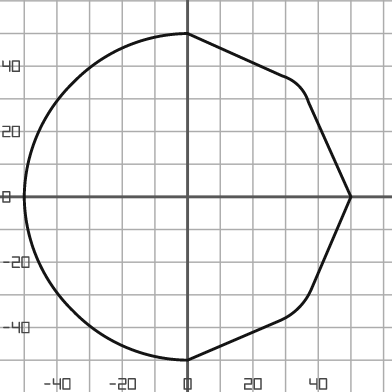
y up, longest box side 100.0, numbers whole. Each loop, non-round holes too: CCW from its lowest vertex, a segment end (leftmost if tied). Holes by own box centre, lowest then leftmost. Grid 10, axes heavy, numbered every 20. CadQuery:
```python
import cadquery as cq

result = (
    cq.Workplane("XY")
    .moveTo(0.0, -50.0)
    .lineTo(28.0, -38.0)
    .threePointArc((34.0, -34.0), (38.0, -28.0))
    .lineTo(50.0, 0.0)
    .lineTo(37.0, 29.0)
    .threePointArc((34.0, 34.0), (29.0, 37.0))
    .lineTo(0.0, 50.0)
    .threePointArc((-19.0, 46.0), (-35.0, 35.0))
    .threePointArc((-46.0, 19.0), (-50.0, 0.0))
    .threePointArc((-46.0, -19.0), (-35.0, -35.0))
    .threePointArc((-19.0, -46.0), (0.0, -50.0))
    .close()
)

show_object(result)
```